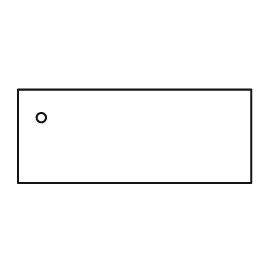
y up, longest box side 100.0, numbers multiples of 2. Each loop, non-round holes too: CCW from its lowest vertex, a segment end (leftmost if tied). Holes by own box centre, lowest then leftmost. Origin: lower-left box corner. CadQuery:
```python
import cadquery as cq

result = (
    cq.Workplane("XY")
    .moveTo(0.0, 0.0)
    .lineTo(100.0, 0.0)
    .lineTo(100.0, 40.0)
    .lineTo(0.0, 40.0)
    .close()
    .moveTo(10.0, 28.0)
    .circle(2.0)
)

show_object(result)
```